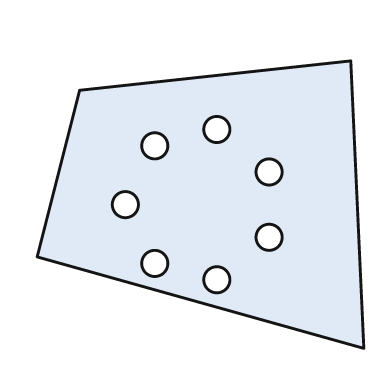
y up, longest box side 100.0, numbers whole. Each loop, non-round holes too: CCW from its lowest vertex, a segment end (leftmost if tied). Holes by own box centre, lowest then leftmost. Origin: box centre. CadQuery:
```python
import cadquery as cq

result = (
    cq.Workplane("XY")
    .moveTo(50.0, -44.0)
    .lineTo(46.0, 44.0)
    .lineTo(-37.0, 35.0)
    .lineTo(-50.0, -16.0)
    .close()
    .moveTo(5.0, -23.0)
    .circle(4.0)
    .moveTo(-14.0, -18.0)
    .circle(4.0)
    .moveTo(21.0, -10.0)
    .circle(4.0)
    .moveTo(-23.0, 0.0)
    .circle(4.0)
    .moveTo(21.0, 10.0)
    .circle(4.0)
    .moveTo(-14.0, 18.0)
    .circle(4.0)
    .moveTo(5.0, 23.0)
    .circle(4.0)
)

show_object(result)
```